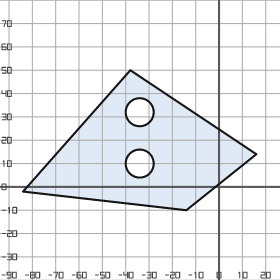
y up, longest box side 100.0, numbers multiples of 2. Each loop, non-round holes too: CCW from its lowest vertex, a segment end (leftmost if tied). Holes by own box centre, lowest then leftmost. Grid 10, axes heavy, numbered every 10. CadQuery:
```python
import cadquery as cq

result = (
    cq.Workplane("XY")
    .moveTo(-14.0, -10.0)
    .lineTo(16.0, 14.0)
    .lineTo(-38.0, 50.0)
    .lineTo(-84.0, -2.0)
    .close()
    .moveTo(-34.0, 10.0)
    .circle(6.0)
    .moveTo(-34.0, 32.0)
    .circle(6.0)
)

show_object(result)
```